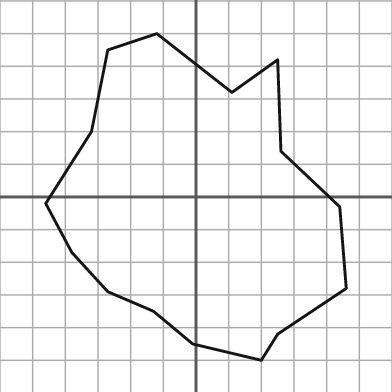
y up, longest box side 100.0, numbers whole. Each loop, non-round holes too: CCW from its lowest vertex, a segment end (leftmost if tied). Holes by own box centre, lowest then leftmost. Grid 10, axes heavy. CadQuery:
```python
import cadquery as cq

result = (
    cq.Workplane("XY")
    .moveTo(20.0, -50.0)
    .lineTo(25.0, -42.0)
    .lineTo(46.0, -28.0)
    .lineTo(44.0, -3.0)
    .lineTo(26.0, 14.0)
    .lineTo(25.0, 42.0)
    .lineTo(11.0, 32.0)
    .lineTo(-12.0, 50.0)
    .lineTo(-27.0, 45.0)
    .lineTo(-32.0, 20.0)
    .lineTo(-46.0, -2.0)
    .lineTo(-38.0, -17.0)
    .lineTo(-27.0, -29.0)
    .lineTo(-13.0, -35.0)
    .lineTo(-1.0, -45.0)
    .close()
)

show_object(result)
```